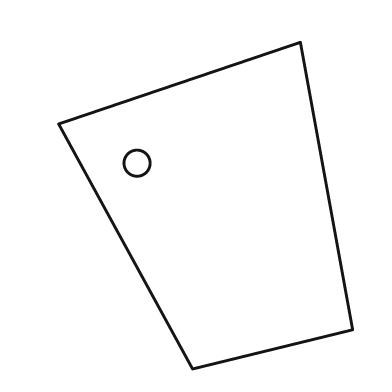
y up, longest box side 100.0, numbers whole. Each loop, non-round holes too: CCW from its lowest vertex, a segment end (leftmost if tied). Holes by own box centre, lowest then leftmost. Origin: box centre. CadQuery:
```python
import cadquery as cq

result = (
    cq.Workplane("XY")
    .moveTo(-4.0, -50.0)
    .lineTo(45.0, -38.0)
    .lineTo(29.0, 50.0)
    .lineTo(-45.0, 25.0)
    .close()
    .moveTo(-21.0, 13.0)
    .circle(4.0)
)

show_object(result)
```